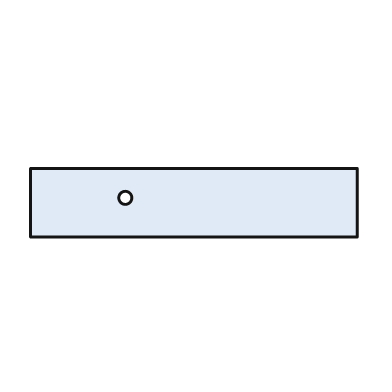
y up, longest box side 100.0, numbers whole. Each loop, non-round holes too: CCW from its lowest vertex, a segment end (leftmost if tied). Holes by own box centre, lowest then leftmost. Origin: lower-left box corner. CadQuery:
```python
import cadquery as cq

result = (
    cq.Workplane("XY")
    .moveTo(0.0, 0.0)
    .lineTo(100.0, 0.0)
    .lineTo(100.0, 21.0)
    .lineTo(0.0, 21.0)
    .close()
    .moveTo(29.0, 12.0)
    .circle(2.0)
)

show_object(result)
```